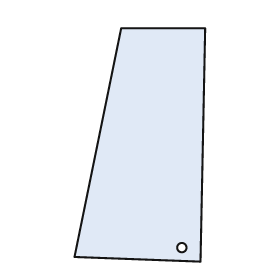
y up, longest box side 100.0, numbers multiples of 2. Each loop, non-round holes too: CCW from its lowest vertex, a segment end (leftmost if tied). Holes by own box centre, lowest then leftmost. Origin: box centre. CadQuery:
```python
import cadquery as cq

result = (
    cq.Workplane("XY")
    .moveTo(26.0, -50.0)
    .lineTo(28.0, 50.0)
    .lineTo(-8.0, 50.0)
    .lineTo(-28.0, -48.0)
    .close()
    .moveTo(18.0, -44.0)
    .circle(2.0)
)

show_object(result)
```